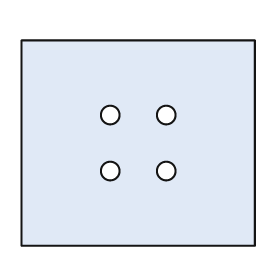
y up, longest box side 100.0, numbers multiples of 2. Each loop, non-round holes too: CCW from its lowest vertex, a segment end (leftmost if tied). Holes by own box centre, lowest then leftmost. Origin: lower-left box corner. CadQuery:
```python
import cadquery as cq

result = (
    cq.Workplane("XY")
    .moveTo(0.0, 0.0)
    .lineTo(100.0, 0.0)
    .lineTo(100.0, 88.0)
    .lineTo(0.0, 88.0)
    .close()
    .moveTo(38.0, 32.0)
    .circle(4.0)
    .moveTo(62.0, 32.0)
    .circle(4.0)
    .moveTo(38.0, 56.0)
    .circle(4.0)
    .moveTo(62.0, 56.0)
    .circle(4.0)
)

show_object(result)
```